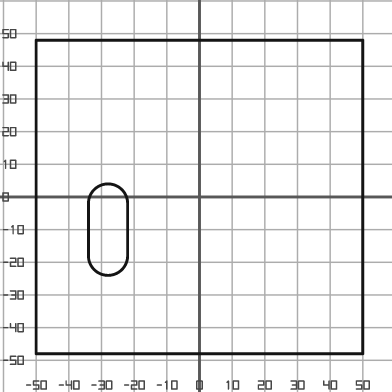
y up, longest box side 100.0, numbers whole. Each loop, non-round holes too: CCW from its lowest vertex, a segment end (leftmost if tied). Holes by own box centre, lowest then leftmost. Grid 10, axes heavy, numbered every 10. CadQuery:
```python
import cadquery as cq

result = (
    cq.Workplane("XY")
    .moveTo(-50.0, -48.0)
    .lineTo(50.0, -48.0)
    .lineTo(50.0, 48.0)
    .lineTo(-50.0, 48.0)
    .close()
    .moveTo(-34.0, -18.0)
    .threePointArc((-28.0, -24.0), (-22.0, -18.0))
    .lineTo(-22.0, -2.0)
    .threePointArc((-28.0, 4.0), (-34.0, -2.0))
    .close()
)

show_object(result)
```